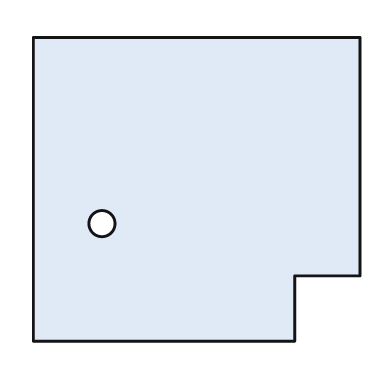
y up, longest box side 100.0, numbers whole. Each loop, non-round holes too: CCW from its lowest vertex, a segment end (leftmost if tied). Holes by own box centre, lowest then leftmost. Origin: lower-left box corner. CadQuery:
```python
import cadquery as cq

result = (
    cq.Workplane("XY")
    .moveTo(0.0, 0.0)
    .lineTo(80.0, 0.0)
    .lineTo(80.0, 20.0)
    .lineTo(100.0, 20.0)
    .lineTo(100.0, 93.0)
    .lineTo(0.0, 93.0)
    .close()
    .moveTo(21.0, 36.0)
    .circle(4.0)
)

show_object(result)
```